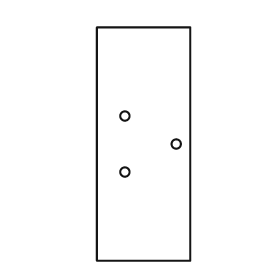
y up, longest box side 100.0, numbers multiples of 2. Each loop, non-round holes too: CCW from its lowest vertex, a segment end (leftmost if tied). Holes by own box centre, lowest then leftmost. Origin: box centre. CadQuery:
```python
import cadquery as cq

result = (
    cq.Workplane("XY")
    .moveTo(-20.0, -50.0)
    .lineTo(20.0, -50.0)
    .lineTo(20.0, 50.0)
    .lineTo(-20.0, 50.0)
    .close()
    .moveTo(-8.0, -12.0)
    .circle(2.0)
    .moveTo(14.0, 0.0)
    .circle(2.0)
    .moveTo(-8.0, 12.0)
    .circle(2.0)
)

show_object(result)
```